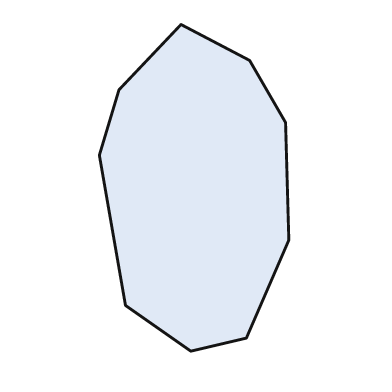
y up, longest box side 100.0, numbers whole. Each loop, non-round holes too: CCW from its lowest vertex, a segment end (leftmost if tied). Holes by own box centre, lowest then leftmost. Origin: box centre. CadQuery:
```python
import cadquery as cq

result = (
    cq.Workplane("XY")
    .moveTo(-1.0, -50.0)
    .lineTo(16.0, -46.0)
    .lineTo(29.0, -16.0)
    .lineTo(28.0, 20.0)
    .lineTo(17.0, 39.0)
    .lineTo(-4.0, 50.0)
    .lineTo(-23.0, 30.0)
    .lineTo(-29.0, 10.0)
    .lineTo(-21.0, -36.0)
    .close()
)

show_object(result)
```